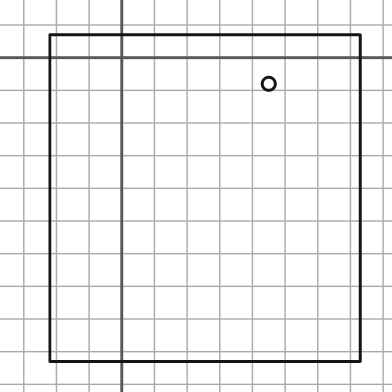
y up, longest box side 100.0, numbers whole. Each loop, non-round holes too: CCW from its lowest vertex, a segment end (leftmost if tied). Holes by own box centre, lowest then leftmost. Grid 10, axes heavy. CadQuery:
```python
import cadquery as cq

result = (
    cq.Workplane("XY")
    .moveTo(-22.0, -93.0)
    .lineTo(73.0, -93.0)
    .lineTo(73.0, 7.0)
    .lineTo(-22.0, 7.0)
    .close()
    .moveTo(45.0, -8.0)
    .circle(2.0)
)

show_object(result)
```